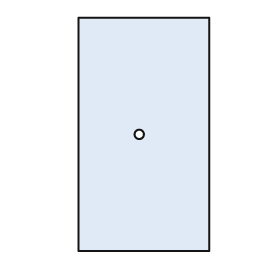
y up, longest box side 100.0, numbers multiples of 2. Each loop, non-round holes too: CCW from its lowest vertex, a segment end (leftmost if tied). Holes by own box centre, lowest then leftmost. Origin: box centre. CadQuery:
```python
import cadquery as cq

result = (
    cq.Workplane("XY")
    .moveTo(-28.0, -50.0)
    .lineTo(28.0, -50.0)
    .lineTo(28.0, 50.0)
    .lineTo(-28.0, 50.0)
    .close()
    .moveTo(-2.0, 0.0)
    .circle(2.0)
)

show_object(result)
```